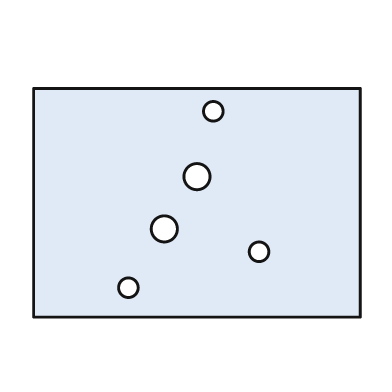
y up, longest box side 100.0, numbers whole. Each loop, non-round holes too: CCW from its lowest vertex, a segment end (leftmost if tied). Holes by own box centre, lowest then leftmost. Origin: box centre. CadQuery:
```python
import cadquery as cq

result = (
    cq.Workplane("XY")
    .moveTo(-50.0, -35.0)
    .lineTo(50.0, -35.0)
    .lineTo(50.0, 35.0)
    .lineTo(-50.0, 35.0)
    .close()
    .moveTo(-21.0, -26.0)
    .circle(3.0)
    .moveTo(19.0, -15.0)
    .circle(3.0)
    .moveTo(-10.0, -8.0)
    .circle(4.0)
    .moveTo(0.0, 8.0)
    .circle(4.0)
    .moveTo(5.0, 28.0)
    .circle(3.0)
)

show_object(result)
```